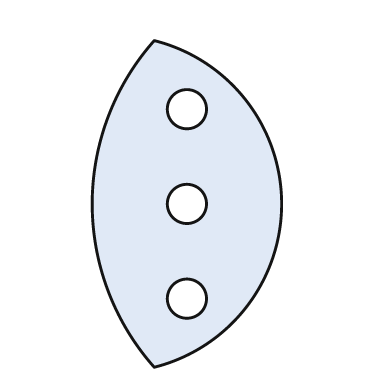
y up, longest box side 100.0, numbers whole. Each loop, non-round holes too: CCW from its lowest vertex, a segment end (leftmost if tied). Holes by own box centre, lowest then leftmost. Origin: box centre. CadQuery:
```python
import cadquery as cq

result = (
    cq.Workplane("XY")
    .moveTo(-10.0, -50.0)
    .threePointArc((29.0, 0.0), (-10.0, 50.0))
    .threePointArc((-29.0, 0.0), (-10.0, -50.0))
    .close()
    .moveTo(0.0, -29.0)
    .circle(6.0)
    .moveTo(0.0, 0.0)
    .circle(6.0)
    .moveTo(0.0, 29.0)
    .circle(6.0)
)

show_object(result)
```